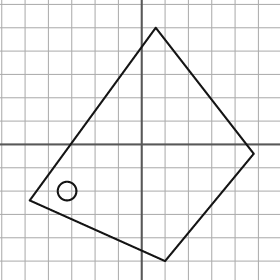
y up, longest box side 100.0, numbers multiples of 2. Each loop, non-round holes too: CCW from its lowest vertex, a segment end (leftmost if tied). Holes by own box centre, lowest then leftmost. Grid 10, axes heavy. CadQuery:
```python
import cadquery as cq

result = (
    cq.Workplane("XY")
    .moveTo(10.0, -50.0)
    .lineTo(48.0, -4.0)
    .lineTo(6.0, 50.0)
    .lineTo(-48.0, -24.0)
    .close()
    .moveTo(-32.0, -20.0)
    .circle(4.0)
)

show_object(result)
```